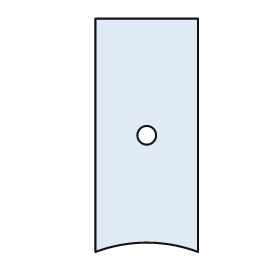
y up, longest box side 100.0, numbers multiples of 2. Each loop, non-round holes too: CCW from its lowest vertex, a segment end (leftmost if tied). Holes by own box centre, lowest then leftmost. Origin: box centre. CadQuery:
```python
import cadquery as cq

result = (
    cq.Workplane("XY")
    .moveTo(-22.0, -50.0)
    .threePointArc((0.0, -46.0), (22.0, -50.0))
    .lineTo(22.0, 50.0)
    .lineTo(-22.0, 50.0)
    .close()
    .moveTo(0.0, 0.0)
    .circle(4.0)
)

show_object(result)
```